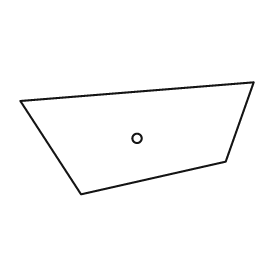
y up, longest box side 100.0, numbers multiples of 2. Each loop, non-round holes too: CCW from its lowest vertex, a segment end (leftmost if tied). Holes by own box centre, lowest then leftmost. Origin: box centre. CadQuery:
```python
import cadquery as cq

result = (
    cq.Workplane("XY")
    .moveTo(-24.0, -24.0)
    .lineTo(38.0, -10.0)
    .lineTo(50.0, 24.0)
    .lineTo(-50.0, 16.0)
    .close()
    .moveTo(0.0, 0.0)
    .circle(2.0)
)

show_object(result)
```